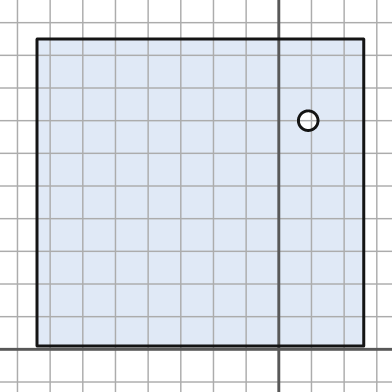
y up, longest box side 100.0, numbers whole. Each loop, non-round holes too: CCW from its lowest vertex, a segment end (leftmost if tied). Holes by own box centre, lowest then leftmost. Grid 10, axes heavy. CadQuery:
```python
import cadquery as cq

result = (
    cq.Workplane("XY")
    .moveTo(-74.0, 1.0)
    .lineTo(26.0, 1.0)
    .lineTo(26.0, 95.0)
    .lineTo(-74.0, 95.0)
    .close()
    .moveTo(9.0, 70.0)
    .circle(3.0)
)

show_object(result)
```